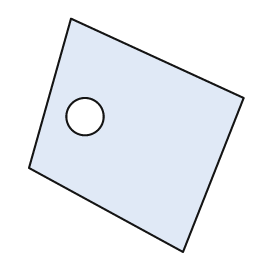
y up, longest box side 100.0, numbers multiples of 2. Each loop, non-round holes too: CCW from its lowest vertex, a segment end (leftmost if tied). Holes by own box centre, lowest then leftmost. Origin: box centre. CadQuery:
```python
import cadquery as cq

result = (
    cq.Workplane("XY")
    .moveTo(20.0, -50.0)
    .lineTo(46.0, 16.0)
    .lineTo(-28.0, 50.0)
    .lineTo(-46.0, -14.0)
    .close()
    .moveTo(-22.0, 8.0)
    .circle(8.0)
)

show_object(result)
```